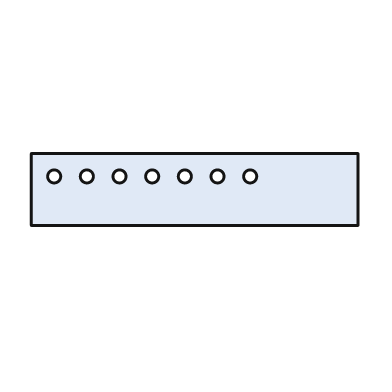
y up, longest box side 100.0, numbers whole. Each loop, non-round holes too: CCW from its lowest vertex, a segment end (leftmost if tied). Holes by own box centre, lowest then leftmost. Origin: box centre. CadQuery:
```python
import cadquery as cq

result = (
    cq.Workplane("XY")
    .moveTo(-50.0, -11.0)
    .lineTo(50.0, -11.0)
    .lineTo(50.0, 11.0)
    .lineTo(-50.0, 11.0)
    .close()
    .moveTo(-43.0, 4.0)
    .circle(2.0)
    .moveTo(-33.0, 4.0)
    .circle(2.0)
    .moveTo(-23.0, 4.0)
    .circle(2.0)
    .moveTo(-13.0, 4.0)
    .circle(2.0)
    .moveTo(-3.0, 4.0)
    .circle(2.0)
    .moveTo(7.0, 4.0)
    .circle(2.0)
    .moveTo(17.0, 4.0)
    .circle(2.0)
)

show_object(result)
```